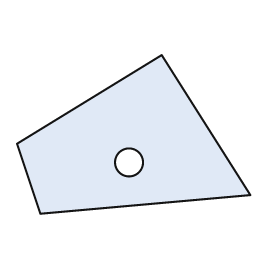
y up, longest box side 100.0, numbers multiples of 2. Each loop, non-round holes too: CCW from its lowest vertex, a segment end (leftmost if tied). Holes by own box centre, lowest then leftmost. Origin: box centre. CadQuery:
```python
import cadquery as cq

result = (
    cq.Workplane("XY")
    .moveTo(-40.0, -34.0)
    .lineTo(50.0, -26.0)
    .lineTo(12.0, 34.0)
    .lineTo(-50.0, -4.0)
    .close()
    .moveTo(-2.0, -12.0)
    .circle(6.0)
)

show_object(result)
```